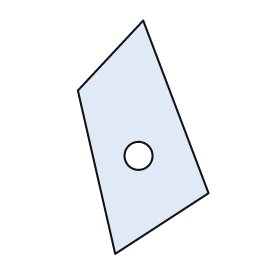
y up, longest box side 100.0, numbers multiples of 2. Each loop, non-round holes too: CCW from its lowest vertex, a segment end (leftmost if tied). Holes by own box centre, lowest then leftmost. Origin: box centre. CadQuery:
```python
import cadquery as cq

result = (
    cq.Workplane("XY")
    .moveTo(-12.0, -50.0)
    .lineTo(28.0, -24.0)
    .lineTo(0.0, 50.0)
    .lineTo(-28.0, 20.0)
    .close()
    .moveTo(-2.0, -8.0)
    .circle(6.0)
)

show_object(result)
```